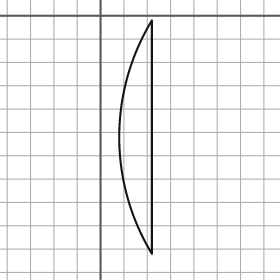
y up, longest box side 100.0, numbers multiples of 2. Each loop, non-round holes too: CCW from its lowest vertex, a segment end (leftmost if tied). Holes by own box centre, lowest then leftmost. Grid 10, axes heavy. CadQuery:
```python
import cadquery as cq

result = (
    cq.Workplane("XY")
    .moveTo(22.0, -102.0)
    .lineTo(22.0, -2.0)
    .threePointArc((8.0, -52.0), (22.0, -102.0))
    .close()
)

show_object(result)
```